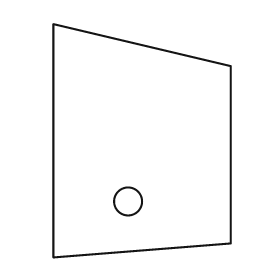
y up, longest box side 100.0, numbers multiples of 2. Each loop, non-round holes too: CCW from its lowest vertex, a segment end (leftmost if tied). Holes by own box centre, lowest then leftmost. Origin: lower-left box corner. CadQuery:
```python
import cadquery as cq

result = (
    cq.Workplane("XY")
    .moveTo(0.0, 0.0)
    .lineTo(76.0, 6.0)
    .lineTo(76.0, 82.0)
    .lineTo(0.0, 100.0)
    .close()
    .moveTo(32.0, 24.0)
    .circle(6.0)
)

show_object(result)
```